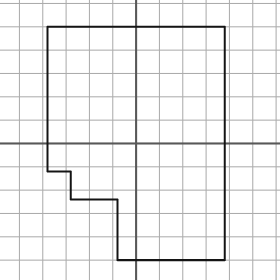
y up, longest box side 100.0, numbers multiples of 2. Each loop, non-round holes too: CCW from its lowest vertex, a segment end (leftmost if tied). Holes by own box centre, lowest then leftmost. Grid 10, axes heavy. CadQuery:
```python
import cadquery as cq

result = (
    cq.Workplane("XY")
    .moveTo(-8.0, -50.0)
    .lineTo(38.0, -50.0)
    .lineTo(38.0, 50.0)
    .lineTo(-38.0, 50.0)
    .lineTo(-38.0, -12.0)
    .lineTo(-28.0, -12.0)
    .lineTo(-28.0, -24.0)
    .lineTo(-8.0, -24.0)
    .close()
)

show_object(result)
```